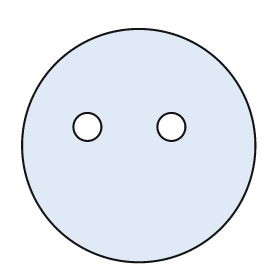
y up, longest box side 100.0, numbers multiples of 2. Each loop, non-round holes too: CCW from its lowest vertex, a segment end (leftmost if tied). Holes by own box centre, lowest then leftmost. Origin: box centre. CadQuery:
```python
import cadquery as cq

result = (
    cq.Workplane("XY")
    .moveTo(0.0, 0.0)
    .circle(50.0)
    .moveTo(-22.0, 8.0)
    .circle(6.0)
    .moveTo(14.0, 8.0)
    .circle(6.0)
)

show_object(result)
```